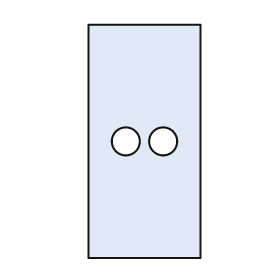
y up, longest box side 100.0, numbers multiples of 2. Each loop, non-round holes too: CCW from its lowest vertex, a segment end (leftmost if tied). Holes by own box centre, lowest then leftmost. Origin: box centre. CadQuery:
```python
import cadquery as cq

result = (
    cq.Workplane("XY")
    .moveTo(-24.0, -50.0)
    .lineTo(24.0, -50.0)
    .lineTo(24.0, 50.0)
    .lineTo(-24.0, 50.0)
    .close()
    .moveTo(-8.0, 0.0)
    .circle(6.0)
    .moveTo(8.0, 0.0)
    .circle(6.0)
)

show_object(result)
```